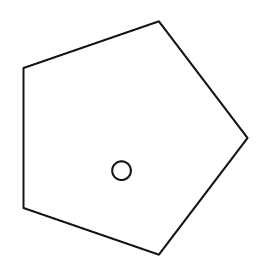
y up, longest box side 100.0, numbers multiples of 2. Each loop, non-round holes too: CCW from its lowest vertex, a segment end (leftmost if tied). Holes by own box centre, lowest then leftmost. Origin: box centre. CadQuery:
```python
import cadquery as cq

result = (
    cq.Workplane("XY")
    .moveTo(10.0, -50.0)
    .lineTo(48.0, 0.0)
    .lineTo(10.0, 50.0)
    .lineTo(-48.0, 30.0)
    .lineTo(-48.0, -30.0)
    .close()
    .moveTo(-6.0, -14.0)
    .circle(4.0)
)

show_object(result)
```